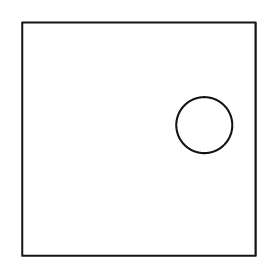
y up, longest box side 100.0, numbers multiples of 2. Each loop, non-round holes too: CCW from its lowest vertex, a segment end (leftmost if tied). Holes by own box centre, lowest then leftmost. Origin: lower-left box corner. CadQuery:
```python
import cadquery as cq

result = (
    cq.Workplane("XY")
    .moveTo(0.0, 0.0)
    .lineTo(100.0, 0.0)
    .lineTo(100.0, 100.0)
    .lineTo(0.0, 100.0)
    .close()
    .moveTo(78.0, 56.0)
    .circle(12.0)
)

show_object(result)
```